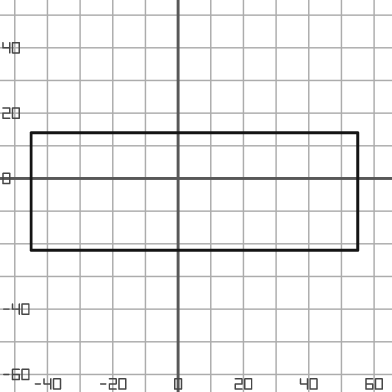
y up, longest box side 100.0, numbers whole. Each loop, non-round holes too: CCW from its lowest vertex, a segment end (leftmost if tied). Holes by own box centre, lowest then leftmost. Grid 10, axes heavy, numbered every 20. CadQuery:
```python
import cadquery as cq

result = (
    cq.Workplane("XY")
    .moveTo(-45.0, -22.0)
    .lineTo(55.0, -22.0)
    .lineTo(55.0, 14.0)
    .lineTo(-45.0, 14.0)
    .close()
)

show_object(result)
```